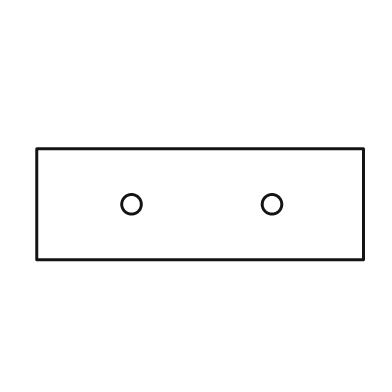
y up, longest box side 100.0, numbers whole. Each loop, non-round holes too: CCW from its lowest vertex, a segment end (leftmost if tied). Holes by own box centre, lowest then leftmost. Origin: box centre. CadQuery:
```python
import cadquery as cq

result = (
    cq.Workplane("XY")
    .moveTo(-50.0, -17.0)
    .lineTo(50.0, -17.0)
    .lineTo(50.0, 17.0)
    .lineTo(-50.0, 17.0)
    .close()
    .moveTo(-21.0, 0.0)
    .circle(3.0)
    .moveTo(22.0, 0.0)
    .circle(3.0)
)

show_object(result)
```